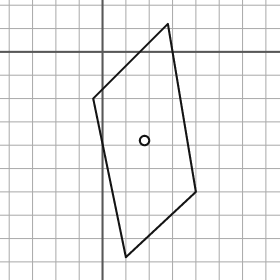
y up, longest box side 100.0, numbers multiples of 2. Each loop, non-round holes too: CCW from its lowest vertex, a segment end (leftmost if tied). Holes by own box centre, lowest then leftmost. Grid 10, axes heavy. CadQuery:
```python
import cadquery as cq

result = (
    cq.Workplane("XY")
    .moveTo(10.0, -88.0)
    .lineTo(40.0, -60.0)
    .lineTo(28.0, 12.0)
    .lineTo(-4.0, -20.0)
    .close()
    .moveTo(18.0, -38.0)
    .circle(2.0)
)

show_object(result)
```